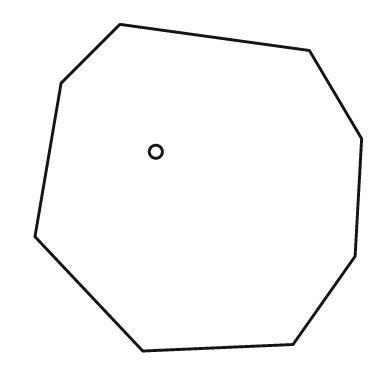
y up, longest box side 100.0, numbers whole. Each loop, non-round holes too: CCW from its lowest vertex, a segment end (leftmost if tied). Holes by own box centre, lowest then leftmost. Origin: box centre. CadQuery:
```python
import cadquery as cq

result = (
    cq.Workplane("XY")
    .moveTo(-17.0, -50.0)
    .lineTo(29.0, -48.0)
    .lineTo(48.0, -21.0)
    .lineTo(50.0, 15.0)
    .lineTo(34.0, 42.0)
    .lineTo(-24.0, 50.0)
    .lineTo(-42.0, 32.0)
    .lineTo(-50.0, -15.0)
    .close()
    .moveTo(-13.0, 11.0)
    .circle(2.0)
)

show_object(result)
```